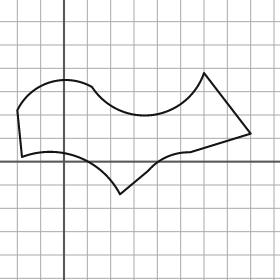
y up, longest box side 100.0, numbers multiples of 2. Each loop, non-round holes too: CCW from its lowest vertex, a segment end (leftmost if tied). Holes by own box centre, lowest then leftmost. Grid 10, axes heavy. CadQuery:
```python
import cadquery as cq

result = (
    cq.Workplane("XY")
    .moveTo(24.0, -14.0)
    .lineTo(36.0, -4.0)
    .threePointArc((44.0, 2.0), (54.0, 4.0))
    .lineTo(80.0, 12.0)
    .lineTo(60.0, 38.0)
    .threePointArc((38.0, 20.0), (12.0, 32.0))
    .threePointArc((-6.0, 34.0), (-20.0, 22.0))
    .lineTo(-18.0, 2.0)
    .threePointArc((6.0, 2.0), (24.0, -14.0))
    .close()
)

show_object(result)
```